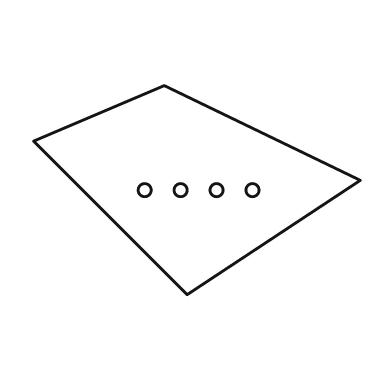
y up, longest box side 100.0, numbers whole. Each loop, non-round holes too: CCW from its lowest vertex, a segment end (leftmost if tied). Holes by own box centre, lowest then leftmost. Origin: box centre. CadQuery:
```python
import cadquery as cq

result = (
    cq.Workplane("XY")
    .moveTo(-3.0, -32.0)
    .lineTo(50.0, 3.0)
    .lineTo(-10.0, 32.0)
    .lineTo(-50.0, 15.0)
    .close()
    .moveTo(-16.0, 0.0)
    .circle(2.0)
    .moveTo(-5.0, 0.0)
    .circle(2.0)
    .moveTo(6.0, 0.0)
    .circle(2.0)
    .moveTo(17.0, 0.0)
    .circle(2.0)
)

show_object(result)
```